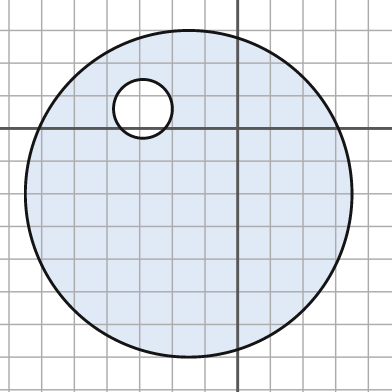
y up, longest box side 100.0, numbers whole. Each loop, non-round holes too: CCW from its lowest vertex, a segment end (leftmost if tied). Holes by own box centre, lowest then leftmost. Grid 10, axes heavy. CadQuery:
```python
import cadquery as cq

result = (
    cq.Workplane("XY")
    .moveTo(-15.0, -20.0)
    .circle(50.0)
    .moveTo(-29.0, 6.0)
    .circle(9.0)
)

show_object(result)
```